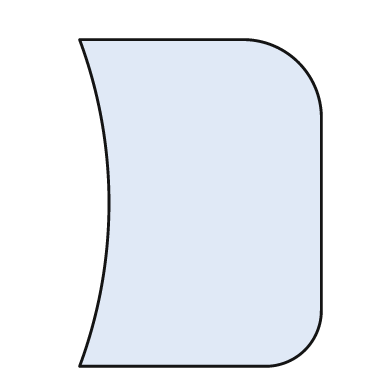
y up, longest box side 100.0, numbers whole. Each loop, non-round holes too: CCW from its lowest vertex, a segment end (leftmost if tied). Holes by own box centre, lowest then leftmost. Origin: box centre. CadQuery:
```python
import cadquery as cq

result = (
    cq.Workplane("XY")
    .moveTo(-37.0, -50.0)
    .lineTo(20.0, -50.0)
    .threePointArc((32.0, -45.0), (37.0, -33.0))
    .lineTo(37.0, 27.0)
    .threePointArc((30.0, 43.0), (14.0, 50.0))
    .lineTo(-37.0, 50.0)
    .threePointArc((-28.0, 0.0), (-37.0, -50.0))
    .close()
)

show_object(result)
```